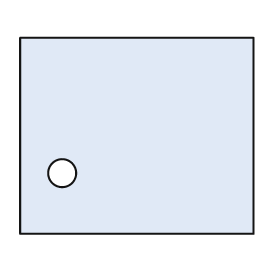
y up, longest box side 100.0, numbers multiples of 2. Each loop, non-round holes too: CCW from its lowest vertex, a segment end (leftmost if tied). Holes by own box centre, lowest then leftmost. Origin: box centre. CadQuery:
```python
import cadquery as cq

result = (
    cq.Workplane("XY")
    .moveTo(-50.0, -42.0)
    .lineTo(50.0, -42.0)
    .lineTo(50.0, 42.0)
    .lineTo(-50.0, 42.0)
    .close()
    .moveTo(-32.0, -16.0)
    .circle(6.0)
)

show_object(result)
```